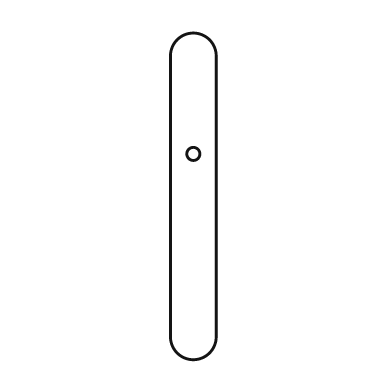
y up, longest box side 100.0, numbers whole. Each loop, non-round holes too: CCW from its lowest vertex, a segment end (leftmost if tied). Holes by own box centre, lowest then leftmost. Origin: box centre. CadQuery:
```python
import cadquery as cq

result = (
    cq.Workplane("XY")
    .moveTo(-7.0, -43.0)
    .threePointArc((0.0, -50.0), (7.0, -43.0))
    .lineTo(7.0, 43.0)
    .threePointArc((0.0, 50.0), (-7.0, 43.0))
    .close()
    .moveTo(0.0, 13.0)
    .circle(2.0)
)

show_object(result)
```